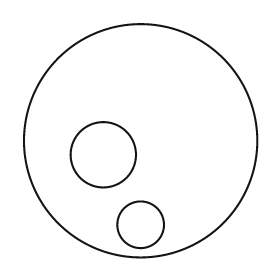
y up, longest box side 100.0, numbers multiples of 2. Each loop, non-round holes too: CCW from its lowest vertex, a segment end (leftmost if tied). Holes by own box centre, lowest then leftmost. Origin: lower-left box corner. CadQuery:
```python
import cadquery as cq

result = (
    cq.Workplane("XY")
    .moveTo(50.0, 50.0)
    .circle(50.0)
    .moveTo(50.0, 14.0)
    .circle(10.0)
    .moveTo(34.0, 44.0)
    .circle(14.0)
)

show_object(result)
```